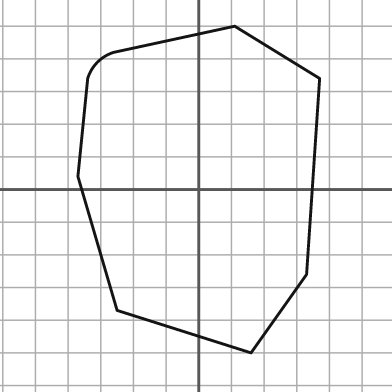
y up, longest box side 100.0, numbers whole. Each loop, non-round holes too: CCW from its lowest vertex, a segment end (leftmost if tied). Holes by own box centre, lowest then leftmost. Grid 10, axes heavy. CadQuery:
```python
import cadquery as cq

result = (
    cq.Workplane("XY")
    .moveTo(16.0, -50.0)
    .lineTo(33.0, -26.0)
    .lineTo(37.0, 34.0)
    .lineTo(11.0, 50.0)
    .lineTo(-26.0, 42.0)
    .threePointArc((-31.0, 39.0), (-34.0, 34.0))
    .lineTo(-37.0, 4.0)
    .lineTo(-25.0, -37.0)
    .close()
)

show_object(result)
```